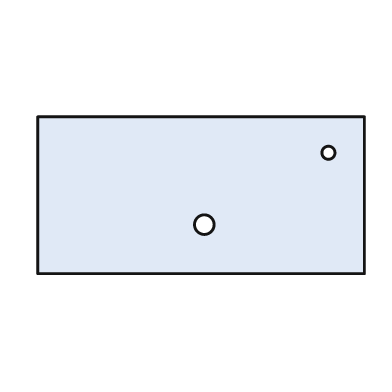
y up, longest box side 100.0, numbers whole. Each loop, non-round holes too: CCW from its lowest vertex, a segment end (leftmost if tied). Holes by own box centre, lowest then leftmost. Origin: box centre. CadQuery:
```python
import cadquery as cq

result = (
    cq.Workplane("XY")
    .moveTo(-50.0, -24.0)
    .lineTo(50.0, -24.0)
    .lineTo(50.0, 24.0)
    .lineTo(-50.0, 24.0)
    .close()
    .moveTo(1.0, -9.0)
    .circle(3.0)
    .moveTo(39.0, 13.0)
    .circle(2.0)
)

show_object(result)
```